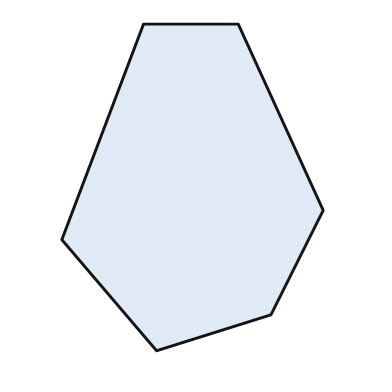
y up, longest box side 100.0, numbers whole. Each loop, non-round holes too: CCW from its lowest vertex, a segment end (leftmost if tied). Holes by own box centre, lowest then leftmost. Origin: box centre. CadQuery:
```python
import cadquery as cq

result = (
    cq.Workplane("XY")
    .moveTo(-11.0, -50.0)
    .lineTo(24.0, -39.0)
    .lineTo(40.0, -7.0)
    .lineTo(14.0, 50.0)
    .lineTo(-15.0, 50.0)
    .lineTo(-40.0, -16.0)
    .close()
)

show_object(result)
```